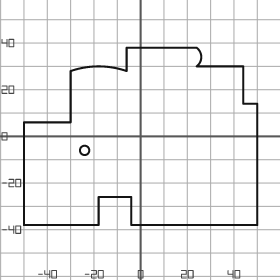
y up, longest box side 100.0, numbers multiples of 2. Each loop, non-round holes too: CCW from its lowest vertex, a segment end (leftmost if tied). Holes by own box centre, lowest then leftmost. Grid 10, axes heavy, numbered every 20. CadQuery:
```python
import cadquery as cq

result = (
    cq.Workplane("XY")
    .moveTo(-50.0, -38.0)
    .lineTo(-18.0, -38.0)
    .lineTo(-18.0, -26.0)
    .lineTo(-4.0, -26.0)
    .lineTo(-4.0, -38.0)
    .lineTo(50.0, -38.0)
    .lineTo(50.0, 14.0)
    .lineTo(44.0, 14.0)
    .lineTo(44.0, 30.0)
    .lineTo(24.0, 30.0)
    .threePointArc((26.0, 34.0), (24.0, 38.0))
    .lineTo(-6.0, 38.0)
    .lineTo(-6.0, 28.0)
    .threePointArc((-18.0, 30.0), (-30.0, 28.0))
    .lineTo(-30.0, 6.0)
    .lineTo(-50.0, 6.0)
    .close()
    .moveTo(-24.0, -6.0)
    .circle(2.0)
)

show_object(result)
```